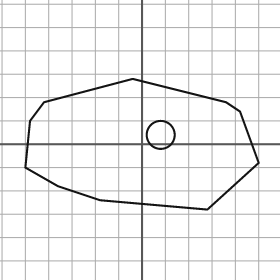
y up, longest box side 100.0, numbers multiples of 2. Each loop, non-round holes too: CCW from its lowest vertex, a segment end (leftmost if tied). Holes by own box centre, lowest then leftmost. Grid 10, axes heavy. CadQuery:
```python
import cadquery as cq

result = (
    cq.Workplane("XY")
    .moveTo(28.0, -28.0)
    .lineTo(50.0, -8.0)
    .lineTo(42.0, 14.0)
    .lineTo(36.0, 18.0)
    .lineTo(-4.0, 28.0)
    .lineTo(-42.0, 18.0)
    .lineTo(-48.0, 10.0)
    .lineTo(-50.0, -10.0)
    .lineTo(-36.0, -18.0)
    .lineTo(-18.0, -24.0)
    .close()
    .moveTo(8.0, 4.0)
    .circle(6.0)
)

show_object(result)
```